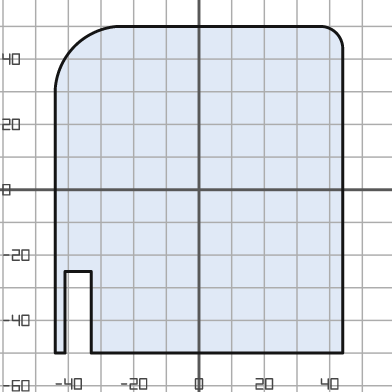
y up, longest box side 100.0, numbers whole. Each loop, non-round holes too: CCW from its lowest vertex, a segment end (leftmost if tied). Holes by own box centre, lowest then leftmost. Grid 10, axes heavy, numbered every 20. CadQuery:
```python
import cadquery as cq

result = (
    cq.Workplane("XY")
    .moveTo(-44.0, -50.0)
    .lineTo(-41.0, -50.0)
    .lineTo(-41.0, -25.0)
    .lineTo(-33.0, -25.0)
    .lineTo(-33.0, -50.0)
    .lineTo(44.0, -50.0)
    .lineTo(44.0, 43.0)
    .threePointArc((42.0, 48.0), (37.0, 50.0))
    .lineTo(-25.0, 50.0)
    .threePointArc((-38.0, 44.0), (-44.0, 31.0))
    .close()
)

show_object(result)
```